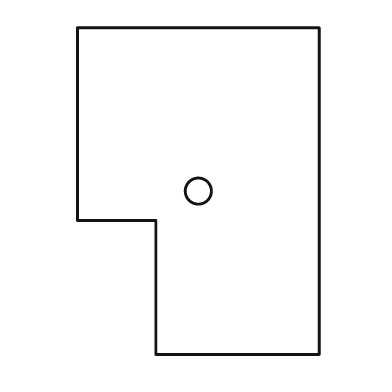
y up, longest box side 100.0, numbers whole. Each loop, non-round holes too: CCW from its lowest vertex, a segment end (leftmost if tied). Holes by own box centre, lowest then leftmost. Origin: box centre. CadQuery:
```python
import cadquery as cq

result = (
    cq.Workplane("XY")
    .moveTo(-13.0, -50.0)
    .lineTo(37.0, -50.0)
    .lineTo(37.0, 50.0)
    .lineTo(-37.0, 50.0)
    .lineTo(-37.0, -9.0)
    .lineTo(-13.0, -9.0)
    .close()
    .moveTo(0.0, 0.0)
    .circle(4.0)
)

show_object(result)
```